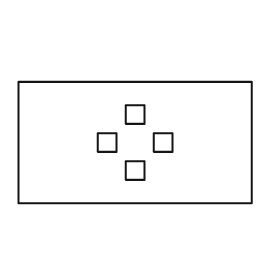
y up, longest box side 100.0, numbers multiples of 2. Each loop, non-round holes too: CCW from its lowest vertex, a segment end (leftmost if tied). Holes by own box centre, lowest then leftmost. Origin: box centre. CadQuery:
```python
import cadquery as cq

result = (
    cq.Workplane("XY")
    .moveTo(-50.0, -26.0)
    .lineTo(50.0, -26.0)
    .lineTo(50.0, 26.0)
    .lineTo(-50.0, 26.0)
    .close()
    .moveTo(-4.0, -16.0)
    .lineTo(4.0, -16.0)
    .lineTo(4.0, -8.0)
    .lineTo(-4.0, -8.0)
    .close()
    .moveTo(-16.0, -4.0)
    .lineTo(-8.0, -4.0)
    .lineTo(-8.0, 4.0)
    .lineTo(-16.0, 4.0)
    .close()
    .moveTo(8.0, -4.0)
    .lineTo(16.0, -4.0)
    .lineTo(16.0, 4.0)
    .lineTo(8.0, 4.0)
    .close()
    .moveTo(-4.0, 8.0)
    .lineTo(4.0, 8.0)
    .lineTo(4.0, 16.0)
    .lineTo(-4.0, 16.0)
    .close()
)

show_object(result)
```